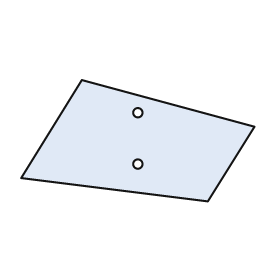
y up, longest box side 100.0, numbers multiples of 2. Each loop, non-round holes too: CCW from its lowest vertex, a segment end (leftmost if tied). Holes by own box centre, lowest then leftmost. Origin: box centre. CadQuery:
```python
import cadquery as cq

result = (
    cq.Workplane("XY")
    .moveTo(30.0, -26.0)
    .lineTo(50.0, 6.0)
    .lineTo(-24.0, 26.0)
    .lineTo(-50.0, -16.0)
    .close()
    .moveTo(0.0, -10.0)
    .circle(2.0)
    .moveTo(0.0, 12.0)
    .circle(2.0)
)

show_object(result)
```